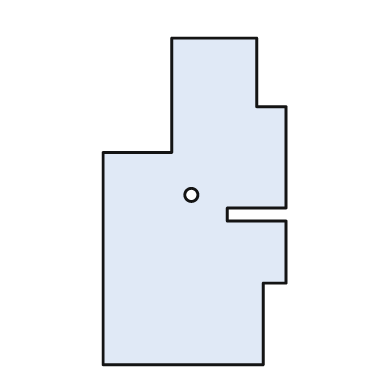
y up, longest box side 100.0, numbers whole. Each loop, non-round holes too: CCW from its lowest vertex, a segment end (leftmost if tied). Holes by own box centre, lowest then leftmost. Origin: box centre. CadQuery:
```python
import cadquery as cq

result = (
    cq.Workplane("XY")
    .moveTo(-28.0, -50.0)
    .lineTo(21.0, -50.0)
    .lineTo(21.0, -25.0)
    .lineTo(28.0, -25.0)
    .lineTo(28.0, -6.0)
    .lineTo(10.0, -6.0)
    .lineTo(10.0, -2.0)
    .lineTo(28.0, -2.0)
    .lineTo(28.0, 29.0)
    .lineTo(19.0, 29.0)
    .lineTo(19.0, 50.0)
    .lineTo(-7.0, 50.0)
    .lineTo(-7.0, 15.0)
    .lineTo(-28.0, 15.0)
    .close()
    .moveTo(-1.0, 2.0)
    .circle(2.0)
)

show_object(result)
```